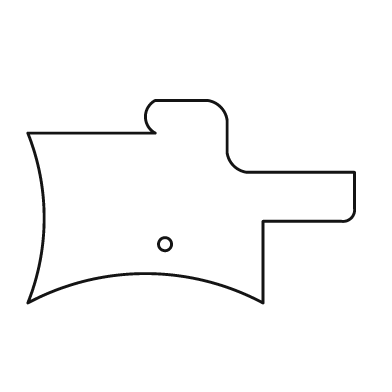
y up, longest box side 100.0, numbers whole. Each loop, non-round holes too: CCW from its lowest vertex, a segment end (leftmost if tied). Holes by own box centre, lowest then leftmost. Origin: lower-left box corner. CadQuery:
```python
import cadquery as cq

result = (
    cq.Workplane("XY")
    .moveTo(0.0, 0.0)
    .threePointArc((36.0, 9.0), (72.0, 0.0))
    .lineTo(72.0, 25.0)
    .lineTo(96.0, 25.0)
    .threePointArc((99.0, 26.0), (100.0, 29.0))
    .lineTo(100.0, 40.0)
    .lineTo(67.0, 40.0)
    .threePointArc((63.0, 42.0), (61.0, 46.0))
    .lineTo(61.0, 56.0)
    .threePointArc((59.0, 60.0), (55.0, 62.0))
    .lineTo(39.0, 62.0)
    .threePointArc((36.0, 57.0), (39.0, 52.0))
    .lineTo(0.0, 52.0)
    .threePointArc((5.0, 26.0), (0.0, 0.0))
    .close()
    .moveTo(42.0, 18.0)
    .circle(2.0)
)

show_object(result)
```